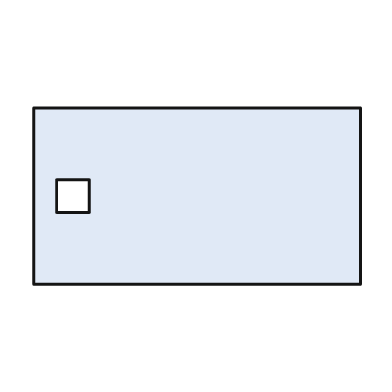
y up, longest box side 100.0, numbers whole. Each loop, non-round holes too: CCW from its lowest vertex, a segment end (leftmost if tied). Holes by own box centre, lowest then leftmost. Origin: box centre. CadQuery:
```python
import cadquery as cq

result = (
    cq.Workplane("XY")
    .moveTo(-50.0, -27.0)
    .lineTo(50.0, -27.0)
    .lineTo(50.0, 27.0)
    .lineTo(-50.0, 27.0)
    .close()
    .moveTo(-43.0, -5.0)
    .lineTo(-33.0, -5.0)
    .lineTo(-33.0, 5.0)
    .lineTo(-43.0, 5.0)
    .close()
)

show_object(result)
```